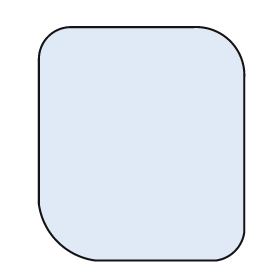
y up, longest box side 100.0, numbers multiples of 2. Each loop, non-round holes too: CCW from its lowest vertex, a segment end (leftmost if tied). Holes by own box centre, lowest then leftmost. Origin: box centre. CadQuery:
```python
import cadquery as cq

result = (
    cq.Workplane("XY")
    .moveTo(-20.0, -50.0)
    .lineTo(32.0, -50.0)
    .threePointArc((40.0, -46.0), (44.0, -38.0))
    .lineTo(44.0, 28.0)
    .threePointArc((38.0, 44.0), (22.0, 50.0))
    .lineTo(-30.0, 50.0)
    .threePointArc((-40.0, 46.0), (-44.0, 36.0))
    .lineTo(-44.0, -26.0)
    .threePointArc((-36.0, -42.0), (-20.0, -50.0))
    .close()
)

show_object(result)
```